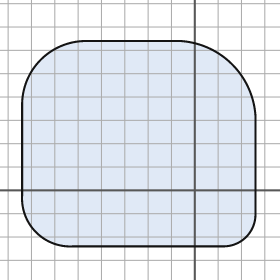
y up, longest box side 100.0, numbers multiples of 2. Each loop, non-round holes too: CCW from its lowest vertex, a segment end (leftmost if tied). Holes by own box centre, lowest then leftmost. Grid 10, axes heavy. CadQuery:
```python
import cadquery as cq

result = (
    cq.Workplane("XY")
    .moveTo(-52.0, -24.0)
    .lineTo(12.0, -24.0)
    .threePointArc((22.0, -20.0), (26.0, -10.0))
    .lineTo(26.0, 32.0)
    .threePointArc((16.0, 54.0), (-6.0, 64.0))
    .lineTo(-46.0, 64.0)
    .threePointArc((-66.0, 56.0), (-74.0, 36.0))
    .lineTo(-74.0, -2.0)
    .threePointArc((-68.0, -18.0), (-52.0, -24.0))
    .close()
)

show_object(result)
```